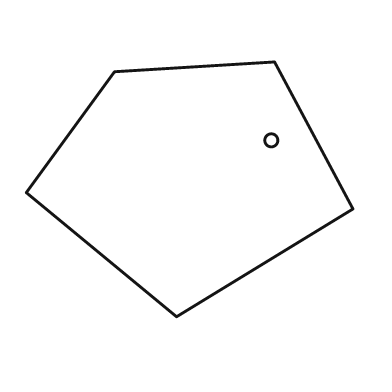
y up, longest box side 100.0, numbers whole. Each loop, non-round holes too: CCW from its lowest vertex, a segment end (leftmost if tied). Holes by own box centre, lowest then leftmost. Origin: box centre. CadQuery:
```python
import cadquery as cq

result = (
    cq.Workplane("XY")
    .moveTo(-4.0, -39.0)
    .lineTo(50.0, -6.0)
    .lineTo(26.0, 39.0)
    .lineTo(-23.0, 36.0)
    .lineTo(-50.0, -1.0)
    .close()
    .moveTo(25.0, 15.0)
    .circle(2.0)
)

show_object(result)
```